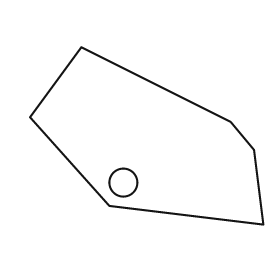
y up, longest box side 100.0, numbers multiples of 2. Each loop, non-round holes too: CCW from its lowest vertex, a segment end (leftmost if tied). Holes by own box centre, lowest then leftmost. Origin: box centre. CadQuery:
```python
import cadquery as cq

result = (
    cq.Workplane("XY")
    .moveTo(50.0, -38.0)
    .lineTo(46.0, -6.0)
    .lineTo(36.0, 6.0)
    .lineTo(-28.0, 38.0)
    .lineTo(-50.0, 8.0)
    .lineTo(-16.0, -30.0)
    .close()
    .moveTo(-10.0, -20.0)
    .circle(6.0)
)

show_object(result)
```